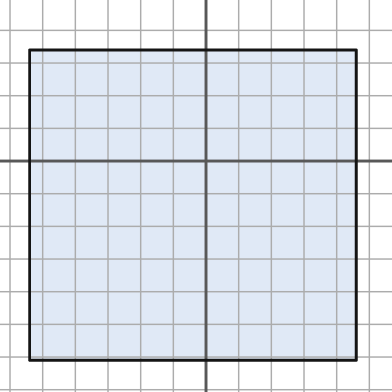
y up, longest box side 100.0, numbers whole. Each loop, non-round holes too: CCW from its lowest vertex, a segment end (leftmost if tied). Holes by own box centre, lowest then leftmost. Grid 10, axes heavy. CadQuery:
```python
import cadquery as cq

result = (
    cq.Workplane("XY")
    .moveTo(-54.0, -61.0)
    .lineTo(46.0, -61.0)
    .lineTo(46.0, 34.0)
    .lineTo(-54.0, 34.0)
    .close()
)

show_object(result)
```